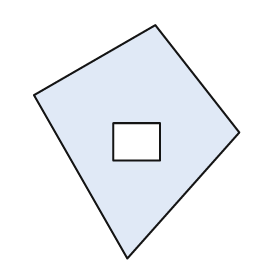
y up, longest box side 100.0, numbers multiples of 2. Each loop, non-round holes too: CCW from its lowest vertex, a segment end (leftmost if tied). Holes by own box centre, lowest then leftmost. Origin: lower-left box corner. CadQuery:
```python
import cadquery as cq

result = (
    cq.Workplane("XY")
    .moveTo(40.0, 0.0)
    .lineTo(88.0, 54.0)
    .lineTo(52.0, 100.0)
    .lineTo(0.0, 70.0)
    .close()
    .moveTo(34.0, 42.0)
    .lineTo(54.0, 42.0)
    .lineTo(54.0, 58.0)
    .lineTo(34.0, 58.0)
    .close()
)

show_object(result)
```